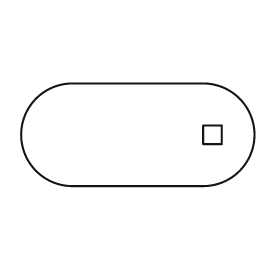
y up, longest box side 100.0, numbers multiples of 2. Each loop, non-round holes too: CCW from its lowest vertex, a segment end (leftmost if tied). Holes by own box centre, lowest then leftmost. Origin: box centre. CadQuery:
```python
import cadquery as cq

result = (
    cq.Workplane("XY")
    .moveTo(-28.0, -22.0)
    .lineTo(28.0, -22.0)
    .threePointArc((50.0, 0.0), (28.0, 22.0))
    .lineTo(-28.0, 22.0)
    .threePointArc((-50.0, 0.0), (-28.0, -22.0))
    .close()
    .moveTo(28.0, -4.0)
    .lineTo(36.0, -4.0)
    .lineTo(36.0, 4.0)
    .lineTo(28.0, 4.0)
    .close()
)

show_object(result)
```